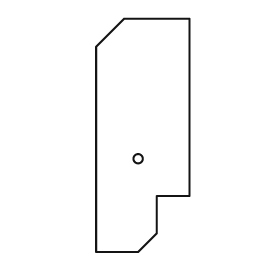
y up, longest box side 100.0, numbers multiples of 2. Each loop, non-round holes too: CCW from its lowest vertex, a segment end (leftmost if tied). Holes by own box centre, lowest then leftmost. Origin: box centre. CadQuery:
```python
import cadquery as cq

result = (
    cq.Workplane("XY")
    .moveTo(-20.0, -50.0)
    .lineTo(-2.0, -50.0)
    .lineTo(6.0, -42.0)
    .lineTo(6.0, -26.0)
    .lineTo(20.0, -26.0)
    .lineTo(20.0, 50.0)
    .lineTo(-8.0, 50.0)
    .lineTo(-20.0, 38.0)
    .close()
    .moveTo(-2.0, -10.0)
    .circle(2.0)
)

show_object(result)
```